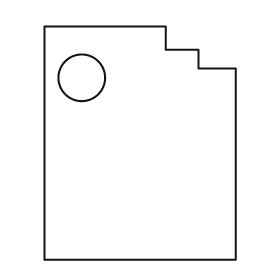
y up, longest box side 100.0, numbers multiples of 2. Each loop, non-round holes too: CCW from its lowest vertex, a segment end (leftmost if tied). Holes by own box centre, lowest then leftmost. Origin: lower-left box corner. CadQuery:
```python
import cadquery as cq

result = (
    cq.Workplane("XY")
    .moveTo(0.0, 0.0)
    .lineTo(82.0, 0.0)
    .lineTo(82.0, 82.0)
    .lineTo(66.0, 82.0)
    .lineTo(66.0, 90.0)
    .lineTo(52.0, 90.0)
    .lineTo(52.0, 100.0)
    .lineTo(0.0, 100.0)
    .close()
    .moveTo(16.0, 78.0)
    .circle(10.0)
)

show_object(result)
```